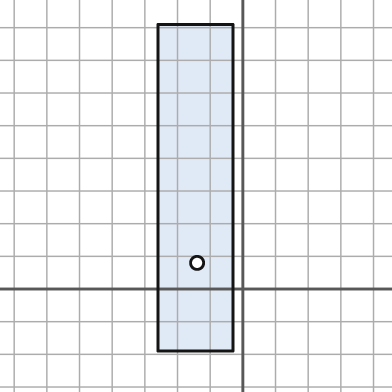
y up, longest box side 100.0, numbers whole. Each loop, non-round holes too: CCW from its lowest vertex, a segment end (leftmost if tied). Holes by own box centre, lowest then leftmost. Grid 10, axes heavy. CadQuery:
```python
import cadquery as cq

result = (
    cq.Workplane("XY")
    .moveTo(-26.0, -19.0)
    .lineTo(-3.0, -19.0)
    .lineTo(-3.0, 81.0)
    .lineTo(-26.0, 81.0)
    .close()
    .moveTo(-14.0, 8.0)
    .circle(2.0)
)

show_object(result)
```